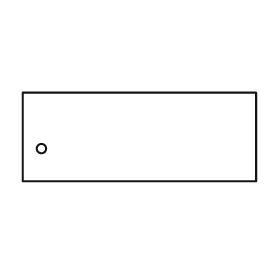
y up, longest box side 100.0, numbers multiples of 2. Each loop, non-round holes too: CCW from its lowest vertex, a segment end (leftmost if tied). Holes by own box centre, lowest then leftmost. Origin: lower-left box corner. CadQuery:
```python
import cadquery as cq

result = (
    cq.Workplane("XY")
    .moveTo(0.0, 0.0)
    .lineTo(100.0, 0.0)
    .lineTo(100.0, 38.0)
    .lineTo(0.0, 38.0)
    .close()
    .moveTo(8.0, 14.0)
    .circle(2.0)
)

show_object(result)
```